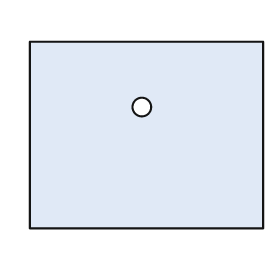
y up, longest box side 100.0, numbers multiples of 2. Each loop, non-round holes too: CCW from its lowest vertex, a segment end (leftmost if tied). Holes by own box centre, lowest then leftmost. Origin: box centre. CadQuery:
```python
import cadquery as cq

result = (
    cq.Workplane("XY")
    .moveTo(-50.0, -40.0)
    .lineTo(50.0, -40.0)
    .lineTo(50.0, 40.0)
    .lineTo(-50.0, 40.0)
    .close()
    .moveTo(-2.0, 12.0)
    .circle(4.0)
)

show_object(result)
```